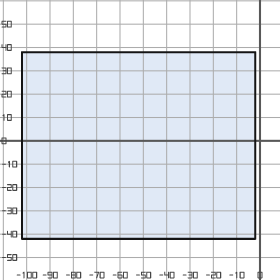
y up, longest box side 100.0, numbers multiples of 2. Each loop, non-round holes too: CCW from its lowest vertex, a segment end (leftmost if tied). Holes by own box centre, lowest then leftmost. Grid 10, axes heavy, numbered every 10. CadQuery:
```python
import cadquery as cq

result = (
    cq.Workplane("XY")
    .moveTo(-102.0, -42.0)
    .lineTo(-2.0, -42.0)
    .lineTo(-2.0, 38.0)
    .lineTo(-102.0, 38.0)
    .close()
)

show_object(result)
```